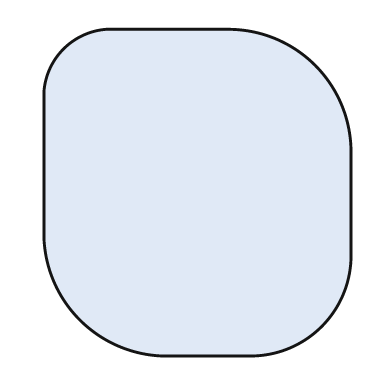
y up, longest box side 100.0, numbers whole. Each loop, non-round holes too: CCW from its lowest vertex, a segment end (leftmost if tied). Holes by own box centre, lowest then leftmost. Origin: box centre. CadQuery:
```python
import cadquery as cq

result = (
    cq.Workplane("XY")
    .moveTo(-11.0, -50.0)
    .lineTo(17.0, -50.0)
    .threePointArc((38.0, -41.0), (47.0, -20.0))
    .lineTo(47.0, 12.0)
    .threePointArc((36.0, 39.0), (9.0, 50.0))
    .lineTo(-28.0, 50.0)
    .threePointArc((-41.0, 44.0), (-47.0, 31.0))
    .lineTo(-47.0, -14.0)
    .threePointArc((-36.0, -39.0), (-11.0, -50.0))
    .close()
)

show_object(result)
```